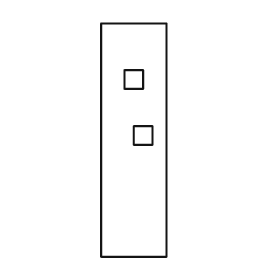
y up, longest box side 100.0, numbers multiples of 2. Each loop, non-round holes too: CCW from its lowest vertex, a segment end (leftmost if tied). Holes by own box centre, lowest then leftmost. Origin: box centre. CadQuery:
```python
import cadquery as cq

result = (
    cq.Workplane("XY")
    .moveTo(-14.0, -50.0)
    .lineTo(14.0, -50.0)
    .lineTo(14.0, 50.0)
    .lineTo(-14.0, 50.0)
    .close()
    .moveTo(0.0, -2.0)
    .lineTo(8.0, -2.0)
    .lineTo(8.0, 6.0)
    .lineTo(0.0, 6.0)
    .close()
    .moveTo(-4.0, 22.0)
    .lineTo(4.0, 22.0)
    .lineTo(4.0, 30.0)
    .lineTo(-4.0, 30.0)
    .close()
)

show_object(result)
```